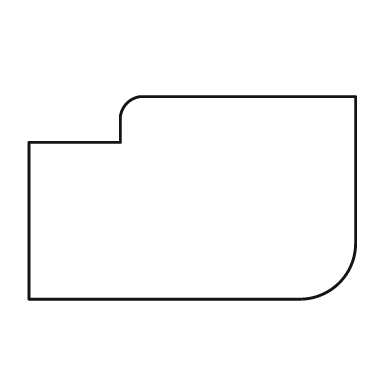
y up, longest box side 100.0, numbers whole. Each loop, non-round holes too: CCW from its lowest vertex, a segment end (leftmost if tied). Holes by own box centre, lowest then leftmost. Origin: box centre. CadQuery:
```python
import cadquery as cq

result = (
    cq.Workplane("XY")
    .moveTo(-50.0, -31.0)
    .lineTo(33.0, -31.0)
    .threePointArc((45.0, -26.0), (50.0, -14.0))
    .lineTo(50.0, 31.0)
    .lineTo(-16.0, 31.0)
    .threePointArc((-20.0, 29.0), (-22.0, 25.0))
    .lineTo(-22.0, 17.0)
    .lineTo(-50.0, 17.0)
    .close()
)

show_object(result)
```